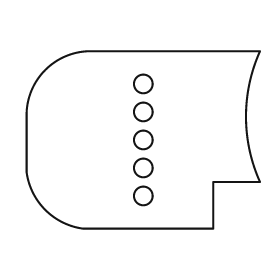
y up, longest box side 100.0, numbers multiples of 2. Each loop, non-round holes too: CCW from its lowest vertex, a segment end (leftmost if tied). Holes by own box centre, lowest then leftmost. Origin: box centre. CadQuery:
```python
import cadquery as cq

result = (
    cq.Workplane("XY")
    .moveTo(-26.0, -38.0)
    .lineTo(30.0, -38.0)
    .lineTo(30.0, -18.0)
    .lineTo(50.0, -18.0)
    .threePointArc((44.0, 10.0), (50.0, 38.0))
    .lineTo(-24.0, 38.0)
    .threePointArc((-42.0, 30.0), (-50.0, 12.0))
    .lineTo(-50.0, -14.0)
    .threePointArc((-42.0, -30.0), (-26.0, -38.0))
    .close()
    .moveTo(0.0, -24.0)
    .circle(4.0)
    .moveTo(0.0, -12.0)
    .circle(4.0)
    .moveTo(0.0, 0.0)
    .circle(4.0)
    .moveTo(0.0, 12.0)
    .circle(4.0)
    .moveTo(0.0, 24.0)
    .circle(4.0)
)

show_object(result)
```